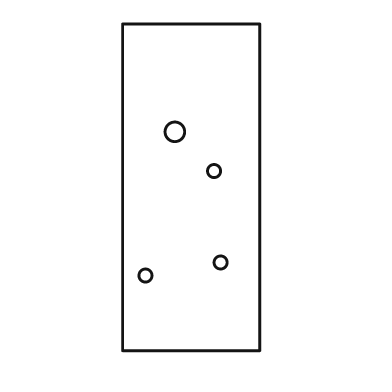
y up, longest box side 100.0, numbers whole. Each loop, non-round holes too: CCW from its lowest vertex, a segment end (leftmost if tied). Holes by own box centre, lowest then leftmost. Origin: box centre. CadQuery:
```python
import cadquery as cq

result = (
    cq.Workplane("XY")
    .moveTo(-21.0, -50.0)
    .lineTo(21.0, -50.0)
    .lineTo(21.0, 50.0)
    .lineTo(-21.0, 50.0)
    .close()
    .moveTo(-14.0, -27.0)
    .circle(2.0)
    .moveTo(9.0, -23.0)
    .circle(2.0)
    .moveTo(7.0, 5.0)
    .circle(2.0)
    .moveTo(-5.0, 17.0)
    .circle(3.0)
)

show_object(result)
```